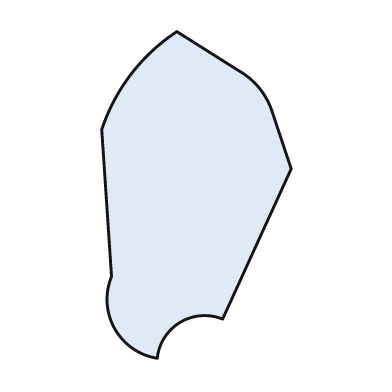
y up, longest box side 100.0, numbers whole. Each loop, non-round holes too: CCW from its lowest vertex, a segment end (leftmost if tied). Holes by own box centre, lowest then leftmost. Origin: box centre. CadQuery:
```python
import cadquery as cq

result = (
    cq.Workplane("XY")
    .moveTo(-12.0, -50.0)
    .threePointArc((-5.0, -39.0), (8.0, -38.0))
    .lineTo(29.0, 8.0)
    .lineTo(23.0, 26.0)
    .threePointArc((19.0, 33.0), (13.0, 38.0))
    .lineTo(-6.0, 50.0)
    .threePointArc((-20.0, 37.0), (-29.0, 20.0))
    .lineTo(-26.0, -25.0)
    .threePointArc((-25.0, -41.0), (-12.0, -50.0))
    .close()
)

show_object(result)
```